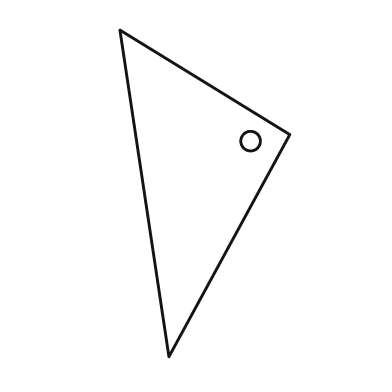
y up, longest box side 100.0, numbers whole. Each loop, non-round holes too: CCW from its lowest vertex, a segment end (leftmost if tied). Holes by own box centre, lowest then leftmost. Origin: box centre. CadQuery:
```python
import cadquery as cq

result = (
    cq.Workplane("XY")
    .moveTo(-11.0, -50.0)
    .lineTo(26.0, 18.0)
    .lineTo(-26.0, 50.0)
    .close()
    .moveTo(14.0, 16.0)
    .circle(3.0)
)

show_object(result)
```